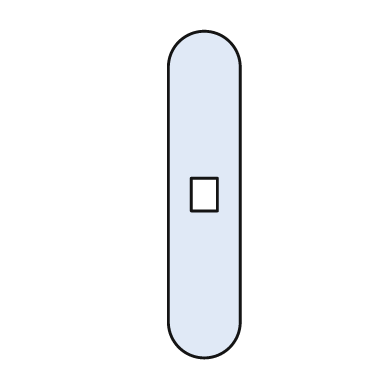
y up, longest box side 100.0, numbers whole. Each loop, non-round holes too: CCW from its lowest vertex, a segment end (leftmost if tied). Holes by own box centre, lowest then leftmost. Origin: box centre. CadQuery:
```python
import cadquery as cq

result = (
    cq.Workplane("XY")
    .moveTo(-11.0, -39.0)
    .threePointArc((0.0, -50.0), (11.0, -39.0))
    .lineTo(11.0, 39.0)
    .threePointArc((0.0, 50.0), (-11.0, 39.0))
    .close()
    .moveTo(-4.0, -5.0)
    .lineTo(4.0, -5.0)
    .lineTo(4.0, 5.0)
    .lineTo(-4.0, 5.0)
    .close()
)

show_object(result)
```